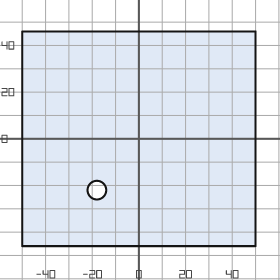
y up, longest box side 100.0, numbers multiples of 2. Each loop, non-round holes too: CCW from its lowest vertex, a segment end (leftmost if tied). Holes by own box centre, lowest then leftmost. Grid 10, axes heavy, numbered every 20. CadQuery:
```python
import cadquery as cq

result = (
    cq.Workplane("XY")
    .moveTo(-50.0, -46.0)
    .lineTo(50.0, -46.0)
    .lineTo(50.0, 46.0)
    .lineTo(-50.0, 46.0)
    .close()
    .moveTo(-18.0, -22.0)
    .circle(4.0)
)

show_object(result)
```